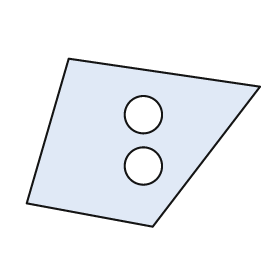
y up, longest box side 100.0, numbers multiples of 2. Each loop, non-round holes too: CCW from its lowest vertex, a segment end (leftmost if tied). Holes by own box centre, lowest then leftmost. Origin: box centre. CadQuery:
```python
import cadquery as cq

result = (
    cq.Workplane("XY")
    .moveTo(4.0, -36.0)
    .lineTo(50.0, 24.0)
    .lineTo(-32.0, 36.0)
    .lineTo(-50.0, -26.0)
    .close()
    .moveTo(0.0, -10.0)
    .circle(8.0)
    .moveTo(0.0, 12.0)
    .circle(8.0)
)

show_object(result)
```